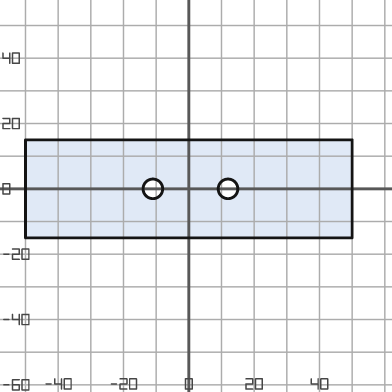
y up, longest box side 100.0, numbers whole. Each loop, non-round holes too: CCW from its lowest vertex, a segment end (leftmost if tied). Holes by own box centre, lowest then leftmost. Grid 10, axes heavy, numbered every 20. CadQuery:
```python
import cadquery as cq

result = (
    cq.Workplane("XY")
    .moveTo(-50.0, -15.0)
    .lineTo(50.0, -15.0)
    .lineTo(50.0, 15.0)
    .lineTo(-50.0, 15.0)
    .close()
    .moveTo(-11.0, 0.0)
    .circle(3.0)
    .moveTo(12.0, 0.0)
    .circle(3.0)
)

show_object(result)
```